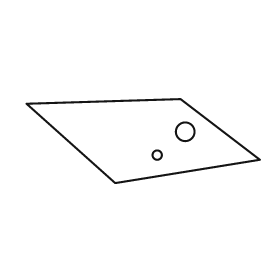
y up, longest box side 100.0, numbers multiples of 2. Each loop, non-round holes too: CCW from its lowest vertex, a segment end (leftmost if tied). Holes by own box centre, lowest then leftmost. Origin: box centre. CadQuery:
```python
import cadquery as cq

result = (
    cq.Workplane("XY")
    .moveTo(-12.0, -18.0)
    .lineTo(50.0, -8.0)
    .lineTo(16.0, 18.0)
    .lineTo(-50.0, 16.0)
    .close()
    .moveTo(6.0, -6.0)
    .circle(2.0)
    .moveTo(18.0, 4.0)
    .circle(4.0)
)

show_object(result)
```